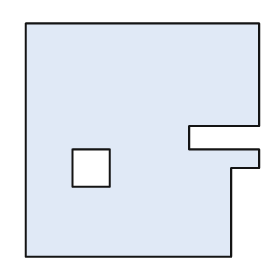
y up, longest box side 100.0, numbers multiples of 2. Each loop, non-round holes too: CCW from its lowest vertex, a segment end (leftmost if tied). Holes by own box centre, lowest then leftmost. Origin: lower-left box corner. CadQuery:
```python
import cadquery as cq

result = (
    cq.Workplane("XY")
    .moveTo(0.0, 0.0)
    .lineTo(88.0, 0.0)
    .lineTo(88.0, 38.0)
    .lineTo(100.0, 38.0)
    .lineTo(100.0, 46.0)
    .lineTo(70.0, 46.0)
    .lineTo(70.0, 56.0)
    .lineTo(100.0, 56.0)
    .lineTo(100.0, 100.0)
    .lineTo(0.0, 100.0)
    .close()
    .moveTo(20.0, 30.0)
    .lineTo(36.0, 30.0)
    .lineTo(36.0, 46.0)
    .lineTo(20.0, 46.0)
    .close()
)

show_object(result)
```